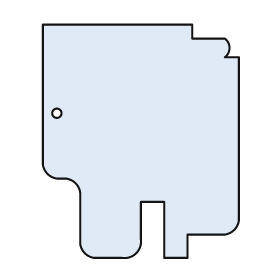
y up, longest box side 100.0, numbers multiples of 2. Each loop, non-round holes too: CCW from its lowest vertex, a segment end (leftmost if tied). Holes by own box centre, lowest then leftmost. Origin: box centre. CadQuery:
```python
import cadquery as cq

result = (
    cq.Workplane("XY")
    .moveTo(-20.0, -50.0)
    .lineTo(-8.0, -50.0)
    .threePointArc((-2.0, -48.0), (0.0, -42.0))
    .lineTo(0.0, -26.0)
    .lineTo(10.0, -26.0)
    .lineTo(10.0, -50.0)
    .lineTo(20.0, -50.0)
    .lineTo(20.0, -40.0)
    .lineTo(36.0, -40.0)
    .threePointArc((40.0, -38.0), (42.0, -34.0))
    .lineTo(42.0, 36.0)
    .lineTo(36.0, 36.0)
    .threePointArc((38.0, 40.0), (36.0, 44.0))
    .lineTo(22.0, 44.0)
    .lineTo(22.0, 50.0)
    .lineTo(-42.0, 50.0)
    .lineTo(-42.0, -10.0)
    .threePointArc((-40.0, -14.0), (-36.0, -16.0))
    .lineTo(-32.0, -16.0)
    .threePointArc((-28.0, -18.0), (-26.0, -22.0))
    .lineTo(-26.0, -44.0)
    .threePointArc((-24.0, -48.0), (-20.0, -50.0))
    .close()
    .moveTo(-36.0, 12.0)
    .circle(2.0)
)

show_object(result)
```